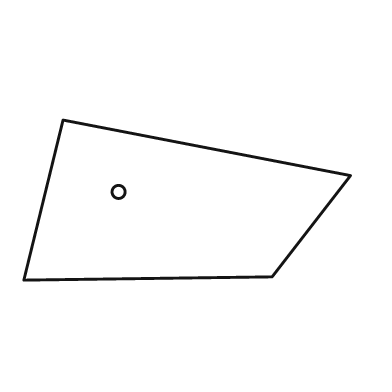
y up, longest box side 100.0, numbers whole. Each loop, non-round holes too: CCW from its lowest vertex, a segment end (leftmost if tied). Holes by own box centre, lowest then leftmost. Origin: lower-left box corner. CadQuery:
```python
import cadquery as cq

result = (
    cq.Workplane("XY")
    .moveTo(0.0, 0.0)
    .lineTo(76.0, 1.0)
    .lineTo(100.0, 32.0)
    .lineTo(12.0, 49.0)
    .close()
    .moveTo(29.0, 27.0)
    .circle(2.0)
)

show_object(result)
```